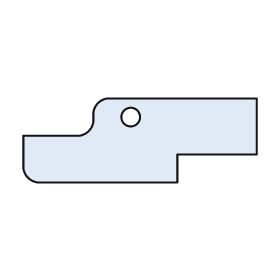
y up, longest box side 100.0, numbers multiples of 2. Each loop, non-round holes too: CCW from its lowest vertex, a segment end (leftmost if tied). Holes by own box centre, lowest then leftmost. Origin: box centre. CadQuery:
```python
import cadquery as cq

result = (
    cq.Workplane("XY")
    .moveTo(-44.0, -18.0)
    .lineTo(16.0, -18.0)
    .lineTo(16.0, -6.0)
    .lineTo(50.0, -6.0)
    .lineTo(50.0, 18.0)
    .lineTo(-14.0, 18.0)
    .threePointArc((-18.0, 16.0), (-20.0, 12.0))
    .lineTo(-20.0, 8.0)
    .threePointArc((-22.0, 4.0), (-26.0, 2.0))
    .lineTo(-50.0, 2.0)
    .lineTo(-50.0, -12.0)
    .threePointArc((-48.0, -16.0), (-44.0, -18.0))
    .close()
    .moveTo(-4.0, 10.0)
    .circle(4.0)
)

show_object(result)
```